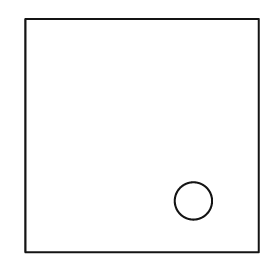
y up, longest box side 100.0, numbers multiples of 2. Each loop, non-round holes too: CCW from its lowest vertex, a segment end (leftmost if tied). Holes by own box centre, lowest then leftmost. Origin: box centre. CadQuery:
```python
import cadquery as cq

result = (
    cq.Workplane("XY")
    .moveTo(-50.0, -50.0)
    .lineTo(50.0, -50.0)
    .lineTo(50.0, 50.0)
    .lineTo(-50.0, 50.0)
    .close()
    .moveTo(22.0, -28.0)
    .circle(8.0)
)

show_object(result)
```